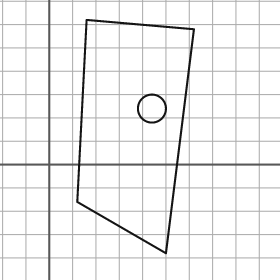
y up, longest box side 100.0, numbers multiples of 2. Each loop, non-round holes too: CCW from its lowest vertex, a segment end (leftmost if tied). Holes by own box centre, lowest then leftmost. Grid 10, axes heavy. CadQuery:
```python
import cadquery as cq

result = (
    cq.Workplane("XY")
    .moveTo(50.0, -38.0)
    .lineTo(62.0, 58.0)
    .lineTo(16.0, 62.0)
    .lineTo(12.0, -16.0)
    .close()
    .moveTo(44.0, 24.0)
    .circle(6.0)
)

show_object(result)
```